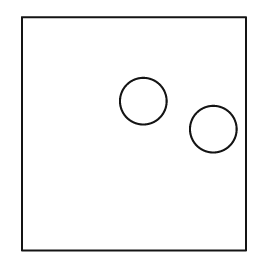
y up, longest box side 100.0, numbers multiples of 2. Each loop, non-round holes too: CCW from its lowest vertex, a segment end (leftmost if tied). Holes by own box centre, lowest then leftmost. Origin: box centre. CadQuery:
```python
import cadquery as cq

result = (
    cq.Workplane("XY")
    .moveTo(-48.0, -50.0)
    .lineTo(48.0, -50.0)
    .lineTo(48.0, 50.0)
    .lineTo(-48.0, 50.0)
    .close()
    .moveTo(34.0, 2.0)
    .circle(10.0)
    .moveTo(4.0, 14.0)
    .circle(10.0)
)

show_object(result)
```